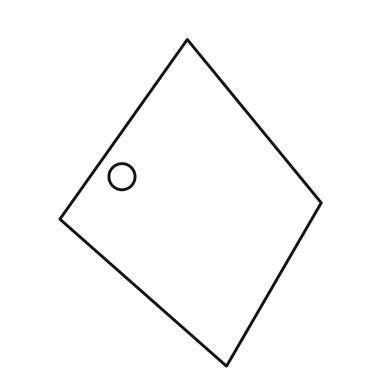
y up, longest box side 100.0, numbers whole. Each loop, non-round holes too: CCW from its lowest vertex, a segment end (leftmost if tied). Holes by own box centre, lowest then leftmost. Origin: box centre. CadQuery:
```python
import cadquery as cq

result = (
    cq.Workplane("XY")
    .moveTo(11.0, -50.0)
    .lineTo(40.0, 0.0)
    .lineTo(-1.0, 50.0)
    .lineTo(-40.0, -5.0)
    .close()
    .moveTo(-21.0, 8.0)
    .circle(4.0)
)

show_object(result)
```